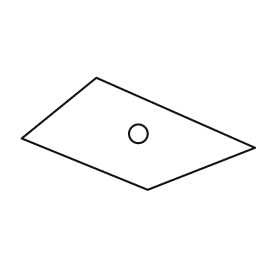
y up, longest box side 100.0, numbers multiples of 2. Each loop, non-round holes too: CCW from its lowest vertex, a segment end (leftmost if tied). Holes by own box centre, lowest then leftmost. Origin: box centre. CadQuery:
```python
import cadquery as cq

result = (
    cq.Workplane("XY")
    .moveTo(4.0, -24.0)
    .lineTo(50.0, -6.0)
    .lineTo(-18.0, 24.0)
    .lineTo(-50.0, -2.0)
    .close()
    .moveTo(0.0, 0.0)
    .circle(4.0)
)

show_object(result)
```